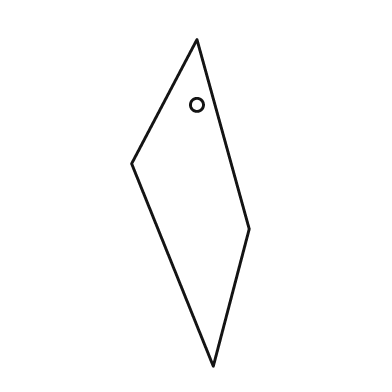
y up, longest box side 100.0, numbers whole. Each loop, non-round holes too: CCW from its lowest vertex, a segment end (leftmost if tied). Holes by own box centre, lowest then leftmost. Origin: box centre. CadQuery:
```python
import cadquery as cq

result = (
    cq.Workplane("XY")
    .moveTo(7.0, -50.0)
    .lineTo(18.0, -8.0)
    .lineTo(2.0, 50.0)
    .lineTo(-18.0, 12.0)
    .close()
    .moveTo(2.0, 30.0)
    .circle(2.0)
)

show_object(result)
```